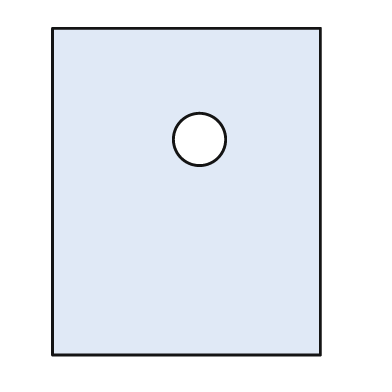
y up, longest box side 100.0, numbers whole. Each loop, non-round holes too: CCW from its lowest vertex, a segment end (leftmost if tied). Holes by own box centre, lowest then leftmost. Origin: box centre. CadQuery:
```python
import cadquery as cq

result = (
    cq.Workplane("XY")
    .moveTo(-41.0, -50.0)
    .lineTo(41.0, -50.0)
    .lineTo(41.0, 50.0)
    .lineTo(-41.0, 50.0)
    .close()
    .moveTo(4.0, 16.0)
    .circle(8.0)
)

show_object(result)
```